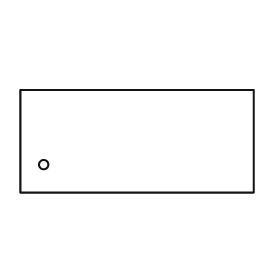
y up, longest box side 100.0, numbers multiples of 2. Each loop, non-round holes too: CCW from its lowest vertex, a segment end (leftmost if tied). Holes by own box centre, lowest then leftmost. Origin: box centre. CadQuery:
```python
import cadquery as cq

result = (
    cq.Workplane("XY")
    .moveTo(-50.0, -22.0)
    .lineTo(50.0, -22.0)
    .lineTo(50.0, 22.0)
    .lineTo(-50.0, 22.0)
    .close()
    .moveTo(-40.0, -10.0)
    .circle(2.0)
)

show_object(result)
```